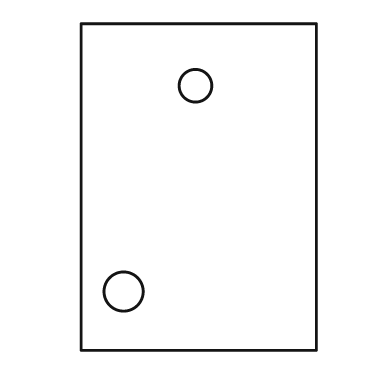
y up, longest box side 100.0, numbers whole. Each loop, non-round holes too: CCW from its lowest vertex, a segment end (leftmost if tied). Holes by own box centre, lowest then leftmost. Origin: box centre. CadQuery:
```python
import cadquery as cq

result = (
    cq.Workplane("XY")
    .moveTo(-36.0, -50.0)
    .lineTo(36.0, -50.0)
    .lineTo(36.0, 50.0)
    .lineTo(-36.0, 50.0)
    .close()
    .moveTo(-23.0, -32.0)
    .circle(6.0)
    .moveTo(-1.0, 31.0)
    .circle(5.0)
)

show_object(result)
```